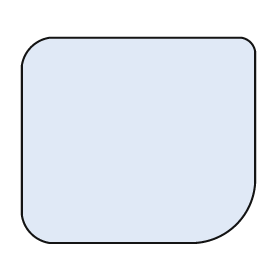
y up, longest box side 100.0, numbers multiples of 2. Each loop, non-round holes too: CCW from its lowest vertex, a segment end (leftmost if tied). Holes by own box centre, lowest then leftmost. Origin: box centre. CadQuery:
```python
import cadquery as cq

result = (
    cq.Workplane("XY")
    .moveTo(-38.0, -44.0)
    .lineTo(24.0, -44.0)
    .threePointArc((42.0, -36.0), (50.0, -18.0))
    .lineTo(50.0, 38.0)
    .threePointArc((48.0, 42.0), (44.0, 44.0))
    .lineTo(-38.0, 44.0)
    .threePointArc((-46.0, 40.0), (-50.0, 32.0))
    .lineTo(-50.0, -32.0)
    .threePointArc((-46.0, -40.0), (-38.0, -44.0))
    .close()
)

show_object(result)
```